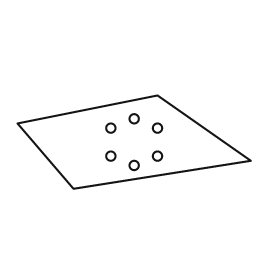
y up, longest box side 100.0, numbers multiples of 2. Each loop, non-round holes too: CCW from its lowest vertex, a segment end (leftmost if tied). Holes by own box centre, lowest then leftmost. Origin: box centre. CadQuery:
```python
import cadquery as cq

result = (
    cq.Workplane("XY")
    .moveTo(-26.0, -20.0)
    .lineTo(50.0, -8.0)
    .lineTo(10.0, 20.0)
    .lineTo(-50.0, 8.0)
    .close()
    .moveTo(0.0, -10.0)
    .circle(2.0)
    .moveTo(-10.0, -6.0)
    .circle(2.0)
    .moveTo(10.0, -6.0)
    .circle(2.0)
    .moveTo(-10.0, 6.0)
    .circle(2.0)
    .moveTo(10.0, 6.0)
    .circle(2.0)
    .moveTo(0.0, 10.0)
    .circle(2.0)
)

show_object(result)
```